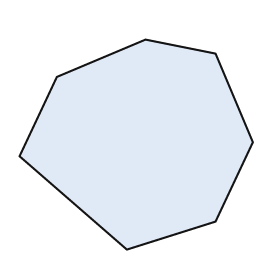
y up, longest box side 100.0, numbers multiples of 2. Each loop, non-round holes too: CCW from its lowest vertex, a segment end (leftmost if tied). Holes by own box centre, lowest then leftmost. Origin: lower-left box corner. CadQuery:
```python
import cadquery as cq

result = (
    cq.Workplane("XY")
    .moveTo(46.0, 0.0)
    .lineTo(84.0, 12.0)
    .lineTo(100.0, 46.0)
    .lineTo(84.0, 84.0)
    .lineTo(54.0, 90.0)
    .lineTo(16.0, 74.0)
    .lineTo(0.0, 40.0)
    .close()
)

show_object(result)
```